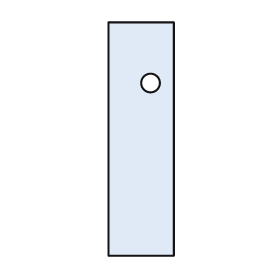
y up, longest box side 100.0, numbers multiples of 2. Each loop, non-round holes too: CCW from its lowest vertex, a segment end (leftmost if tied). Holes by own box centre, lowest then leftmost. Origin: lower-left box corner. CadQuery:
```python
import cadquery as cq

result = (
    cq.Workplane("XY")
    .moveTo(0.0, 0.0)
    .lineTo(28.0, 0.0)
    .lineTo(28.0, 100.0)
    .lineTo(0.0, 100.0)
    .close()
    .moveTo(18.0, 74.0)
    .circle(4.0)
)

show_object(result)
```